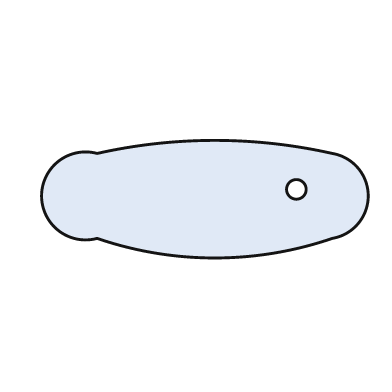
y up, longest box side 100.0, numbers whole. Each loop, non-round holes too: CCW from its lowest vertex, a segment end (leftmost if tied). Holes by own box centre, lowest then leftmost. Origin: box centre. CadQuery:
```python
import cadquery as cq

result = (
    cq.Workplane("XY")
    .moveTo(-33.0, -12.0)
    .threePointArc((3.0, -18.0), (39.0, -12.0))
    .threePointArc((50.0, 1.0), (39.0, 14.0))
    .threePointArc((3.0, 18.0), (-33.0, 14.0))
    .threePointArc((-50.0, 1.0), (-33.0, -12.0))
    .close()
    .moveTo(28.0, 3.0)
    .circle(3.0)
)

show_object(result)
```